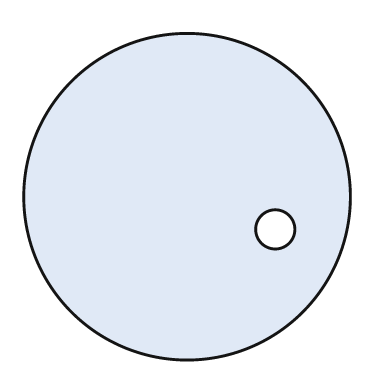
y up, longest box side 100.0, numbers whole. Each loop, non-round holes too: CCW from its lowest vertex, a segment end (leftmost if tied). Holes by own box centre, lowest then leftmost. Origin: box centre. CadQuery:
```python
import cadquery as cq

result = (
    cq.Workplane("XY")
    .moveTo(0.0, 0.0)
    .circle(50.0)
    .moveTo(27.0, -10.0)
    .circle(6.0)
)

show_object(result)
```